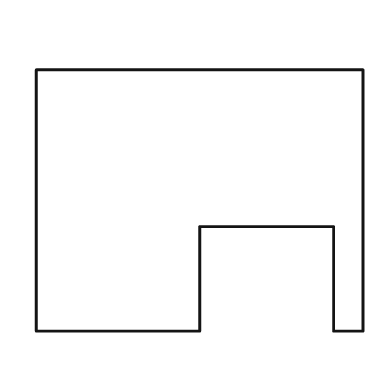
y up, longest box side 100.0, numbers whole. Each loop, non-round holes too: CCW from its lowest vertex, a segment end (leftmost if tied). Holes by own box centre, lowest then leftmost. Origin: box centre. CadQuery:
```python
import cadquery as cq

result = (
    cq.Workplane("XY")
    .moveTo(-50.0, -40.0)
    .lineTo(0.0, -40.0)
    .lineTo(0.0, -8.0)
    .lineTo(41.0, -8.0)
    .lineTo(41.0, -40.0)
    .lineTo(50.0, -40.0)
    .lineTo(50.0, 40.0)
    .lineTo(-50.0, 40.0)
    .close()
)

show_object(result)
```